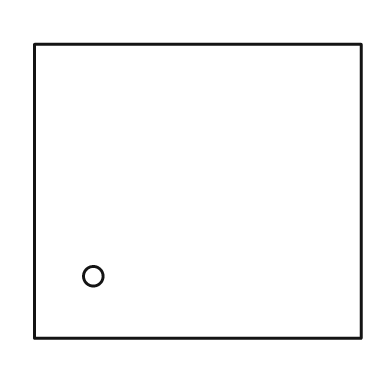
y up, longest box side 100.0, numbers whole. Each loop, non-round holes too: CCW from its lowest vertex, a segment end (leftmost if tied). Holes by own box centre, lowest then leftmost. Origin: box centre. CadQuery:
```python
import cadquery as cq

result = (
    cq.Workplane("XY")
    .moveTo(-50.0, -45.0)
    .lineTo(50.0, -45.0)
    .lineTo(50.0, 45.0)
    .lineTo(-50.0, 45.0)
    .close()
    .moveTo(-32.0, -26.0)
    .circle(3.0)
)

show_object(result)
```